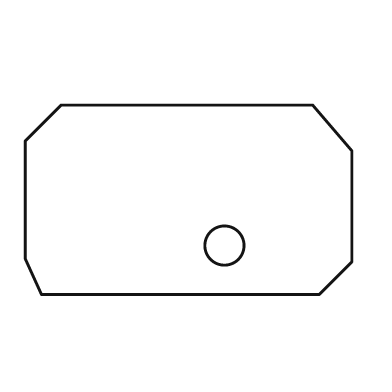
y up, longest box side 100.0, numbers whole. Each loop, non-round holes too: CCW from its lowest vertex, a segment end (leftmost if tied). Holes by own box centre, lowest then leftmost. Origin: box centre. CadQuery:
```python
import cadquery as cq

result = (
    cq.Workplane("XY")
    .moveTo(-45.0, -29.0)
    .lineTo(40.0, -29.0)
    .lineTo(50.0, -19.0)
    .lineTo(50.0, 15.0)
    .lineTo(38.0, 29.0)
    .lineTo(-39.0, 29.0)
    .lineTo(-50.0, 18.0)
    .lineTo(-50.0, -18.0)
    .close()
    .moveTo(11.0, -14.0)
    .circle(6.0)
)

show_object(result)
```